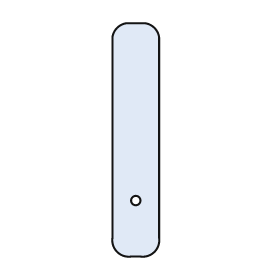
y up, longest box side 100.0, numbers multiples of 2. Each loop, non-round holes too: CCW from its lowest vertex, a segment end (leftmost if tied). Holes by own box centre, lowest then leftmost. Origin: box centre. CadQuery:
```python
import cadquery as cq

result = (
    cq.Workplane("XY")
    .moveTo(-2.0, -50.0)
    .lineTo(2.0, -50.0)
    .threePointArc((8.0, -48.0), (10.0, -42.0))
    .lineTo(10.0, 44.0)
    .threePointArc((8.0, 48.0), (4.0, 50.0))
    .lineTo(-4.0, 50.0)
    .threePointArc((-8.0, 48.0), (-10.0, 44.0))
    .lineTo(-10.0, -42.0)
    .threePointArc((-8.0, -48.0), (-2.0, -50.0))
    .close()
    .moveTo(0.0, -26.0)
    .circle(2.0)
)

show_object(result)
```